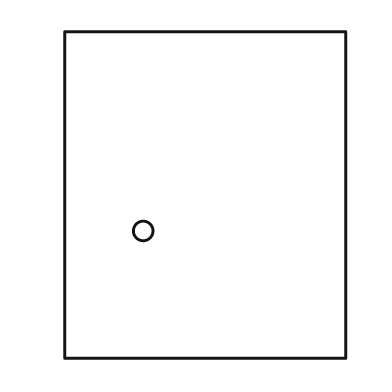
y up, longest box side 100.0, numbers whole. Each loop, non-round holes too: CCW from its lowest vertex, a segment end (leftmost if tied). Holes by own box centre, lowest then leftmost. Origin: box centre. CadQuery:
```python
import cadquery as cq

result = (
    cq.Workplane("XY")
    .moveTo(-43.0, -50.0)
    .lineTo(43.0, -50.0)
    .lineTo(43.0, 50.0)
    .lineTo(-43.0, 50.0)
    .close()
    .moveTo(-19.0, -11.0)
    .circle(3.0)
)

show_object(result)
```